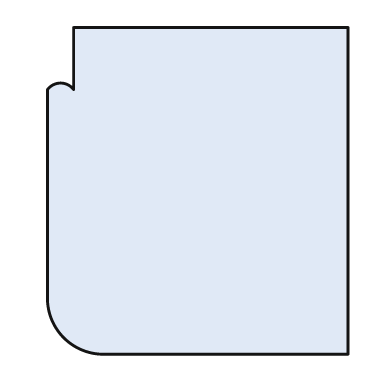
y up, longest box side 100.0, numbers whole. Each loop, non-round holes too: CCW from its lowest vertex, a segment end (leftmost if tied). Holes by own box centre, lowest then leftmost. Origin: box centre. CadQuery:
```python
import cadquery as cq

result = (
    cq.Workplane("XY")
    .moveTo(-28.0, -50.0)
    .lineTo(46.0, -50.0)
    .lineTo(46.0, 50.0)
    .lineTo(-38.0, 50.0)
    .lineTo(-38.0, 31.0)
    .threePointArc((-42.0, 33.0), (-46.0, 31.0))
    .lineTo(-46.0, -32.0)
    .threePointArc((-41.0, -45.0), (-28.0, -50.0))
    .close()
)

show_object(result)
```